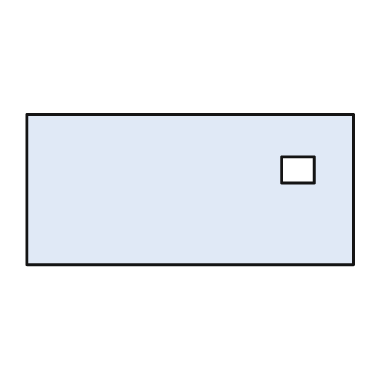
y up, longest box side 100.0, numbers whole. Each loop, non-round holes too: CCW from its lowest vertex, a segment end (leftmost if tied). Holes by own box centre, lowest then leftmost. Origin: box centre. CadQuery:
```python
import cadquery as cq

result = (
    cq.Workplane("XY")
    .moveTo(-50.0, -23.0)
    .lineTo(50.0, -23.0)
    .lineTo(50.0, 23.0)
    .lineTo(-50.0, 23.0)
    .close()
    .moveTo(28.0, 2.0)
    .lineTo(38.0, 2.0)
    .lineTo(38.0, 10.0)
    .lineTo(28.0, 10.0)
    .close()
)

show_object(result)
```